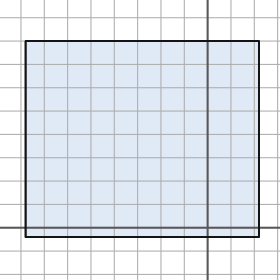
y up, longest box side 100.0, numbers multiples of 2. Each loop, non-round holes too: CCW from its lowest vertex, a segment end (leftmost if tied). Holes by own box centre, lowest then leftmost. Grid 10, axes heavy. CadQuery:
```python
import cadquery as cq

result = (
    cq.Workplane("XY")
    .moveTo(-78.0, -4.0)
    .lineTo(22.0, -4.0)
    .lineTo(22.0, 80.0)
    .lineTo(-78.0, 80.0)
    .close()
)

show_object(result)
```